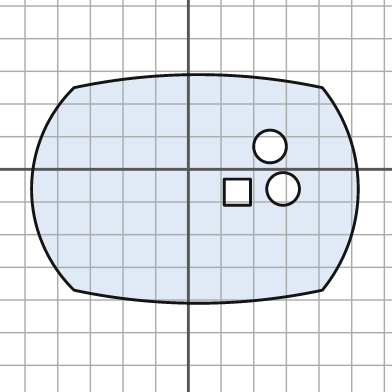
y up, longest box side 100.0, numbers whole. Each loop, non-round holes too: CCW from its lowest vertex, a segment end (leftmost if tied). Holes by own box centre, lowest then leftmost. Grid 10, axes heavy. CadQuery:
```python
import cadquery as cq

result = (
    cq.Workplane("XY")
    .moveTo(-35.0, -37.0)
    .threePointArc((3.0, -41.0), (41.0, -37.0))
    .threePointArc((52.0, -6.0), (41.0, 25.0))
    .threePointArc((3.0, 29.0), (-35.0, 25.0))
    .threePointArc((-48.0, -6.0), (-35.0, -37.0))
    .close()
    .moveTo(11.0, -11.0)
    .lineTo(19.0, -11.0)
    .lineTo(19.0, -3.0)
    .lineTo(11.0, -3.0)
    .close()
    .moveTo(29.0, -6.0)
    .circle(5.0)
    .moveTo(25.0, 7.0)
    .circle(5.0)
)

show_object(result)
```